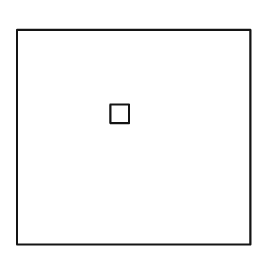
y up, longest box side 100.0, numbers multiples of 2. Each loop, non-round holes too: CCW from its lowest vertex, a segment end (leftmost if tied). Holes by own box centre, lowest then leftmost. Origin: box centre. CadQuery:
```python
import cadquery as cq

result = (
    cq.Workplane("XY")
    .moveTo(-50.0, -46.0)
    .lineTo(50.0, -46.0)
    .lineTo(50.0, 46.0)
    .lineTo(-50.0, 46.0)
    .close()
    .moveTo(-10.0, 6.0)
    .lineTo(-2.0, 6.0)
    .lineTo(-2.0, 14.0)
    .lineTo(-10.0, 14.0)
    .close()
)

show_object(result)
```